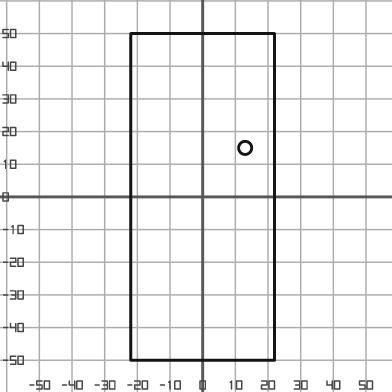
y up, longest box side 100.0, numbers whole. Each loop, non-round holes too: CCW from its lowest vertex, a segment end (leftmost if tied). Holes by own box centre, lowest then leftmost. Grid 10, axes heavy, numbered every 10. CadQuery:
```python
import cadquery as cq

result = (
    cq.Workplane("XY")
    .moveTo(-22.0, -50.0)
    .lineTo(22.0, -50.0)
    .lineTo(22.0, 50.0)
    .lineTo(-22.0, 50.0)
    .close()
    .moveTo(13.0, 15.0)
    .circle(2.0)
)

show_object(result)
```